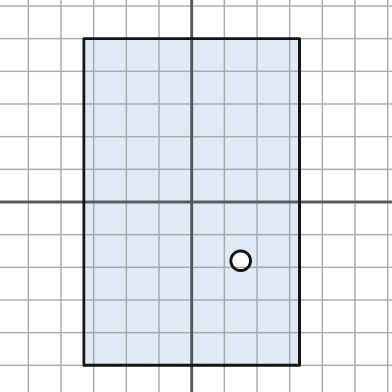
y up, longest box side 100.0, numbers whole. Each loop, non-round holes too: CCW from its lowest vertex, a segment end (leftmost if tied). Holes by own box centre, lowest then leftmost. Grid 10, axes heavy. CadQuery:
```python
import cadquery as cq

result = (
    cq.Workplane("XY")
    .moveTo(-33.0, -50.0)
    .lineTo(33.0, -50.0)
    .lineTo(33.0, 50.0)
    .lineTo(-33.0, 50.0)
    .close()
    .moveTo(15.0, -18.0)
    .circle(3.0)
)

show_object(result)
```